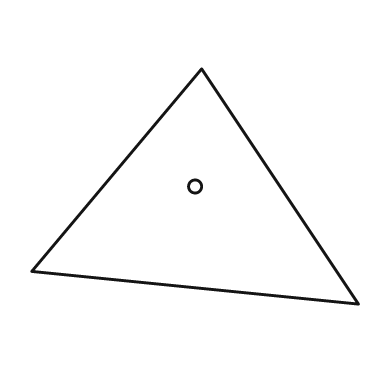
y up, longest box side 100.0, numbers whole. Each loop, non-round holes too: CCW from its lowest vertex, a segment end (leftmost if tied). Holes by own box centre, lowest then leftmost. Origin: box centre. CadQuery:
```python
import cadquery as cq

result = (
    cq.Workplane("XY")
    .moveTo(50.0, -36.0)
    .lineTo(2.0, 36.0)
    .lineTo(-50.0, -26.0)
    .close()
    .moveTo(0.0, 0.0)
    .circle(2.0)
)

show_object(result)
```